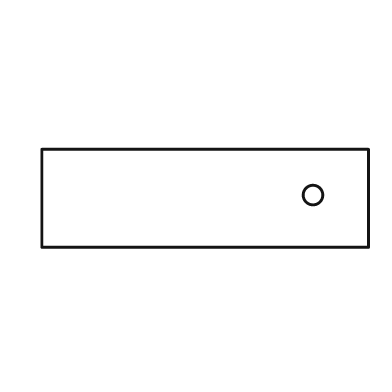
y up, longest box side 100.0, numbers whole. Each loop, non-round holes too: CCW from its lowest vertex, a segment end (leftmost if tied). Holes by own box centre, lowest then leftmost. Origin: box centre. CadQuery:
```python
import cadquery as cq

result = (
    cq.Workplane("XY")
    .moveTo(-50.0, -15.0)
    .lineTo(50.0, -15.0)
    .lineTo(50.0, 15.0)
    .lineTo(-50.0, 15.0)
    .close()
    .moveTo(33.0, 1.0)
    .circle(3.0)
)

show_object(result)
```